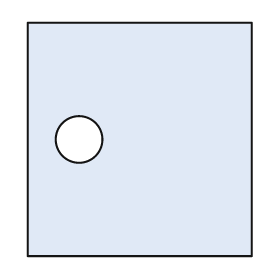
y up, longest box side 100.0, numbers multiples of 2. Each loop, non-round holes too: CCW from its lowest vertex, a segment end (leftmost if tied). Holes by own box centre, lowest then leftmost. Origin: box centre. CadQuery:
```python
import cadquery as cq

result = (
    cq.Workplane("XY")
    .moveTo(-48.0, -50.0)
    .lineTo(48.0, -50.0)
    .lineTo(48.0, 50.0)
    .lineTo(-48.0, 50.0)
    .close()
    .moveTo(-26.0, 0.0)
    .circle(10.0)
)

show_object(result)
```